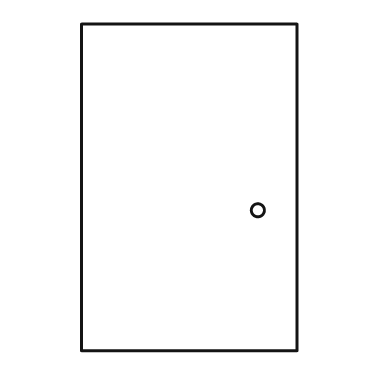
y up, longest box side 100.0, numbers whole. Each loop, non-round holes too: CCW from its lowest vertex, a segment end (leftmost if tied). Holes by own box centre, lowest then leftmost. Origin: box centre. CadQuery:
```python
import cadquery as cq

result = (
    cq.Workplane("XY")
    .moveTo(-33.0, -50.0)
    .lineTo(33.0, -50.0)
    .lineTo(33.0, 50.0)
    .lineTo(-33.0, 50.0)
    .close()
    .moveTo(21.0, -7.0)
    .circle(2.0)
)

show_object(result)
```